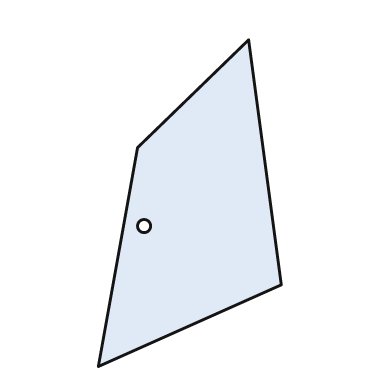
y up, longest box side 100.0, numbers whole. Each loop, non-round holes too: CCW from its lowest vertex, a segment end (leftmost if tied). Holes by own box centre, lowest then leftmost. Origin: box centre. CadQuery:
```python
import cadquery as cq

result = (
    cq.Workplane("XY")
    .moveTo(-28.0, -50.0)
    .lineTo(28.0, -25.0)
    .lineTo(18.0, 50.0)
    .lineTo(-16.0, 17.0)
    .close()
    .moveTo(-14.0, -7.0)
    .circle(2.0)
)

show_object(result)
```